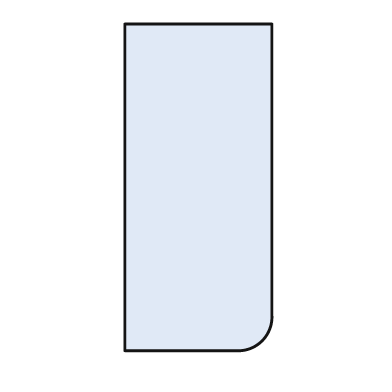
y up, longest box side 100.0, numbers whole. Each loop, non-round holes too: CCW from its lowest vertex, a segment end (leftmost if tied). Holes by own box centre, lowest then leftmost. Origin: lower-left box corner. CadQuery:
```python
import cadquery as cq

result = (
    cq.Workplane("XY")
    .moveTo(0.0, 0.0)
    .lineTo(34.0, 0.0)
    .threePointArc((42.0, 3.0), (45.0, 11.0))
    .lineTo(45.0, 100.0)
    .lineTo(0.0, 100.0)
    .close()
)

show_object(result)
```